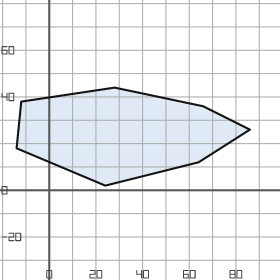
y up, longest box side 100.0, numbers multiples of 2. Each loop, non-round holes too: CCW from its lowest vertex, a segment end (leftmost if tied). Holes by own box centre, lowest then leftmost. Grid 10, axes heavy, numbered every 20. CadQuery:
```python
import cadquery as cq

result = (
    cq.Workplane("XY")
    .moveTo(24.0, 2.0)
    .lineTo(64.0, 12.0)
    .lineTo(86.0, 26.0)
    .lineTo(66.0, 36.0)
    .lineTo(28.0, 44.0)
    .lineTo(-12.0, 38.0)
    .lineTo(-14.0, 18.0)
    .close()
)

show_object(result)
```